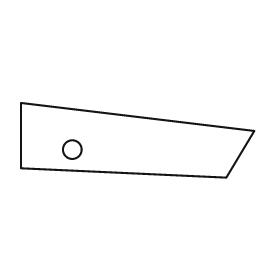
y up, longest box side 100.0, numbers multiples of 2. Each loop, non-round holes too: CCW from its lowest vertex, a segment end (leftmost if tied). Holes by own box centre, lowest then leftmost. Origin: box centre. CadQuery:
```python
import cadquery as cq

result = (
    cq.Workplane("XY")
    .moveTo(38.0, -16.0)
    .lineTo(50.0, 4.0)
    .lineTo(-50.0, 16.0)
    .lineTo(-50.0, -12.0)
    .close()
    .moveTo(-28.0, -4.0)
    .circle(4.0)
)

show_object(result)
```